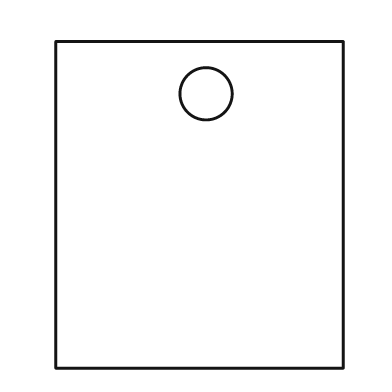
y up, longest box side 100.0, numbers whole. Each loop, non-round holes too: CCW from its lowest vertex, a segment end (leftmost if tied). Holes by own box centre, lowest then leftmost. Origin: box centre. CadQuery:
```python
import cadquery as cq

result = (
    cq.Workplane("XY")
    .moveTo(-44.0, -50.0)
    .lineTo(44.0, -50.0)
    .lineTo(44.0, 50.0)
    .lineTo(-44.0, 50.0)
    .close()
    .moveTo(2.0, 34.0)
    .circle(8.0)
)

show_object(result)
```